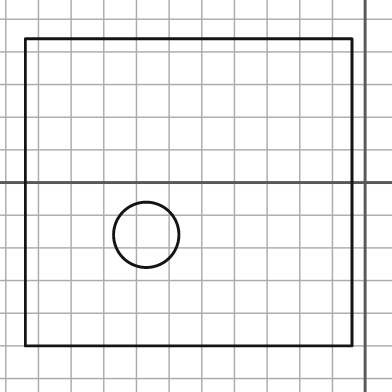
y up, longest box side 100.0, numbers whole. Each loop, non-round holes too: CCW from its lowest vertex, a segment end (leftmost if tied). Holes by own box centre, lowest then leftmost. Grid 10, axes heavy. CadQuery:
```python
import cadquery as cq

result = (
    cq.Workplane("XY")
    .moveTo(-104.0, -50.0)
    .lineTo(-4.0, -50.0)
    .lineTo(-4.0, 44.0)
    .lineTo(-104.0, 44.0)
    .close()
    .moveTo(-67.0, -16.0)
    .circle(10.0)
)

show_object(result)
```